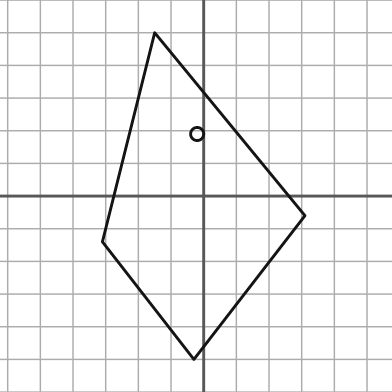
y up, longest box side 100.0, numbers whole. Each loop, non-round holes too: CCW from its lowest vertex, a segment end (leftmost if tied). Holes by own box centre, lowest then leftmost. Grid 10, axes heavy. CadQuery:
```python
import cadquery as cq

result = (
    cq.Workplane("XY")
    .moveTo(-3.0, -50.0)
    .lineTo(31.0, -6.0)
    .lineTo(-15.0, 50.0)
    .lineTo(-31.0, -14.0)
    .close()
    .moveTo(-2.0, 19.0)
    .circle(2.0)
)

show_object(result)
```